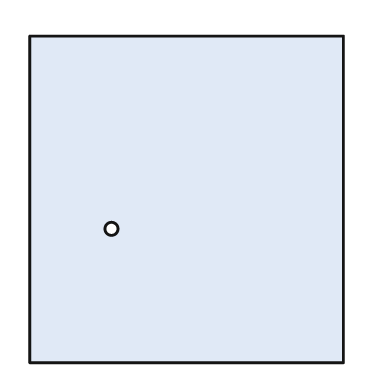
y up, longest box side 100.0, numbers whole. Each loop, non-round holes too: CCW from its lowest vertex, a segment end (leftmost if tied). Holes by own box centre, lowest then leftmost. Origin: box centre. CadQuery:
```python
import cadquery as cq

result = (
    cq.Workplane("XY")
    .moveTo(-48.0, -50.0)
    .lineTo(48.0, -50.0)
    .lineTo(48.0, 50.0)
    .lineTo(-48.0, 50.0)
    .close()
    .moveTo(-23.0, -9.0)
    .circle(2.0)
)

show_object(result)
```